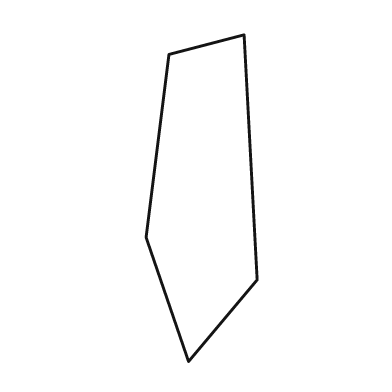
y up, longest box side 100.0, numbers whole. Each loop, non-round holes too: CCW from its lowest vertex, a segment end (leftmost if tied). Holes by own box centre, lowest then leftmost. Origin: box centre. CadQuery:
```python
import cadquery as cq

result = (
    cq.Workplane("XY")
    .moveTo(-4.0, -50.0)
    .lineTo(17.0, -25.0)
    .lineTo(13.0, 50.0)
    .lineTo(-10.0, 44.0)
    .lineTo(-17.0, -12.0)
    .close()
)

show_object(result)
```